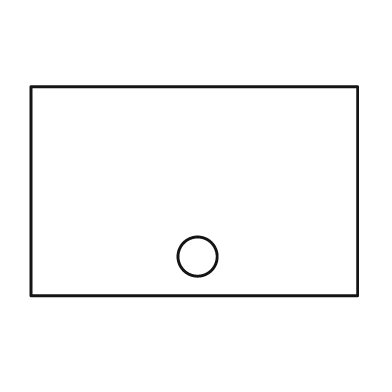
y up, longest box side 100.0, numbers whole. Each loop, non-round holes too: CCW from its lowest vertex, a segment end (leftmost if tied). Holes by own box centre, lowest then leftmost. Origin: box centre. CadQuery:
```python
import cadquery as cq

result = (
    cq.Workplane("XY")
    .moveTo(-50.0, -32.0)
    .lineTo(50.0, -32.0)
    .lineTo(50.0, 32.0)
    .lineTo(-50.0, 32.0)
    .close()
    .moveTo(1.0, -20.0)
    .circle(6.0)
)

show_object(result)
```